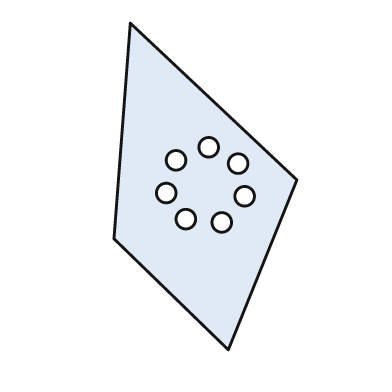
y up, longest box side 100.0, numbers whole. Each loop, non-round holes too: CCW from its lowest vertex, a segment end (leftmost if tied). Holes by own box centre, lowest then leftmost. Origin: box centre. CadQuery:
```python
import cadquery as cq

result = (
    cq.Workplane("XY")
    .moveTo(7.0, -50.0)
    .lineTo(28.0, 2.0)
    .lineTo(-23.0, 50.0)
    .lineTo(-28.0, -16.0)
    .close()
    .moveTo(5.0, -11.0)
    .circle(3.0)
    .moveTo(-6.0, -10.0)
    .circle(3.0)
    .moveTo(12.0, -3.0)
    .circle(3.0)
    .moveTo(-12.0, -2.0)
    .circle(3.0)
    .moveTo(10.0, 7.0)
    .circle(3.0)
    .moveTo(-9.0, 8.0)
    .circle(3.0)
    .moveTo(1.0, 12.0)
    .circle(3.0)
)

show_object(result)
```